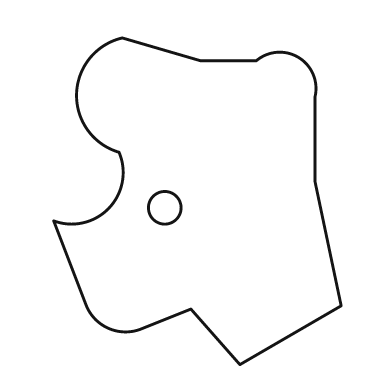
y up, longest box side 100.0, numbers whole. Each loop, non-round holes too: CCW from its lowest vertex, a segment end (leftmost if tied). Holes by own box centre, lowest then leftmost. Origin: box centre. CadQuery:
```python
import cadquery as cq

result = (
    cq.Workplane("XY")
    .moveTo(13.0, -50.0)
    .lineTo(44.0, -32.0)
    .lineTo(36.0, 6.0)
    .lineTo(36.0, 32.0)
    .threePointArc((31.0, 44.0), (18.0, 43.0))
    .lineTo(1.0, 43.0)
    .lineTo(-23.0, 50.0)
    .threePointArc((-37.0, 33.0), (-24.0, 15.0))
    .threePointArc((-27.0, -2.0), (-44.0, -6.0))
    .lineTo(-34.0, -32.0)
    .threePointArc((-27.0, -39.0), (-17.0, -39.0))
    .lineTo(-2.0, -33.0)
    .close()
    .moveTo(-10.0, -2.0)
    .circle(5.0)
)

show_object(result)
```